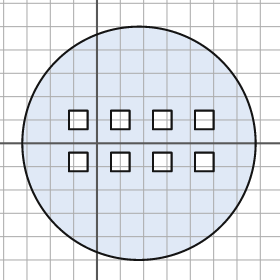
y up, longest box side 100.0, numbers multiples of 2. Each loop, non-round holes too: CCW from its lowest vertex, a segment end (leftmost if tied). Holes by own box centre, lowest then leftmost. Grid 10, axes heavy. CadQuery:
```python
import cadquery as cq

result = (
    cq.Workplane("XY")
    .moveTo(18.0, 0.0)
    .circle(50.0)
    .moveTo(-12.0, -12.0)
    .lineTo(-4.0, -12.0)
    .lineTo(-4.0, -4.0)
    .lineTo(-12.0, -4.0)
    .close()
    .moveTo(6.0, -12.0)
    .lineTo(14.0, -12.0)
    .lineTo(14.0, -4.0)
    .lineTo(6.0, -4.0)
    .close()
    .moveTo(24.0, -12.0)
    .lineTo(32.0, -12.0)
    .lineTo(32.0, -4.0)
    .lineTo(24.0, -4.0)
    .close()
    .moveTo(42.0, -12.0)
    .lineTo(50.0, -12.0)
    .lineTo(50.0, -4.0)
    .lineTo(42.0, -4.0)
    .close()
    .moveTo(-12.0, 6.0)
    .lineTo(-4.0, 6.0)
    .lineTo(-4.0, 14.0)
    .lineTo(-12.0, 14.0)
    .close()
    .moveTo(6.0, 6.0)
    .lineTo(14.0, 6.0)
    .lineTo(14.0, 14.0)
    .lineTo(6.0, 14.0)
    .close()
    .moveTo(24.0, 6.0)
    .lineTo(32.0, 6.0)
    .lineTo(32.0, 14.0)
    .lineTo(24.0, 14.0)
    .close()
    .moveTo(42.0, 6.0)
    .lineTo(50.0, 6.0)
    .lineTo(50.0, 14.0)
    .lineTo(42.0, 14.0)
    .close()
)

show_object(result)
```